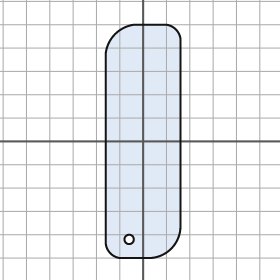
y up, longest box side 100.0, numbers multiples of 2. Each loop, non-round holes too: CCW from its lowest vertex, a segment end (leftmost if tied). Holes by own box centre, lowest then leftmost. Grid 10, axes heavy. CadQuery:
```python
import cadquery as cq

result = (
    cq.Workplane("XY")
    .moveTo(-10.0, -50.0)
    .lineTo(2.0, -50.0)
    .threePointArc((12.0, -46.0), (16.0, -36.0))
    .lineTo(16.0, 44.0)
    .threePointArc((14.0, 48.0), (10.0, 50.0))
    .lineTo(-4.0, 50.0)
    .threePointArc((-12.0, 46.0), (-16.0, 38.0))
    .lineTo(-16.0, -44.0)
    .threePointArc((-14.0, -48.0), (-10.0, -50.0))
    .close()
    .moveTo(-6.0, -42.0)
    .circle(2.0)
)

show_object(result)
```